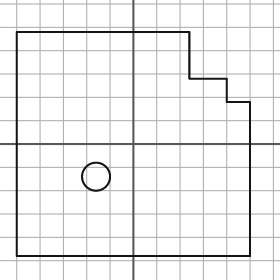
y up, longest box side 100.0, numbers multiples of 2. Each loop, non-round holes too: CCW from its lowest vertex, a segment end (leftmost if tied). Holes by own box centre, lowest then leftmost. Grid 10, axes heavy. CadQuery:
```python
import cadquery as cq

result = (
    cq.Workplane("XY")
    .moveTo(-50.0, -48.0)
    .lineTo(50.0, -48.0)
    .lineTo(50.0, 18.0)
    .lineTo(40.0, 18.0)
    .lineTo(40.0, 28.0)
    .lineTo(24.0, 28.0)
    .lineTo(24.0, 48.0)
    .lineTo(-50.0, 48.0)
    .close()
    .moveTo(-16.0, -14.0)
    .circle(6.0)
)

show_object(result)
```